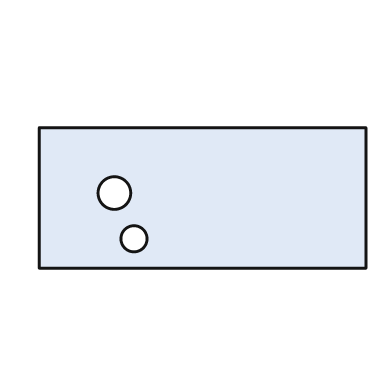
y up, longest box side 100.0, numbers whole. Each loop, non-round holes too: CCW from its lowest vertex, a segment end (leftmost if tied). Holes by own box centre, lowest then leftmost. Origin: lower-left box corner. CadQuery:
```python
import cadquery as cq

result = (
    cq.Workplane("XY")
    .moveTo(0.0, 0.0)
    .lineTo(100.0, 0.0)
    .lineTo(100.0, 43.0)
    .lineTo(0.0, 43.0)
    .close()
    .moveTo(29.0, 9.0)
    .circle(4.0)
    .moveTo(23.0, 23.0)
    .circle(5.0)
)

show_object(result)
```